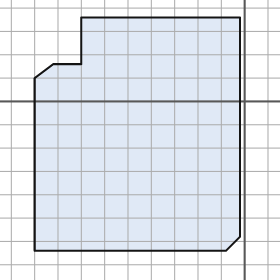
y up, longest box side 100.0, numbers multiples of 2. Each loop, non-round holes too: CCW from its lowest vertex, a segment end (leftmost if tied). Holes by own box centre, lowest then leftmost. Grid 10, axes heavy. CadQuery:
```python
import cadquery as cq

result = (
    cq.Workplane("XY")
    .moveTo(-90.0, -64.0)
    .lineTo(-8.0, -64.0)
    .lineTo(-2.0, -58.0)
    .lineTo(-2.0, 36.0)
    .lineTo(-70.0, 36.0)
    .lineTo(-70.0, 16.0)
    .lineTo(-82.0, 16.0)
    .lineTo(-90.0, 10.0)
    .close()
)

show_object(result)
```